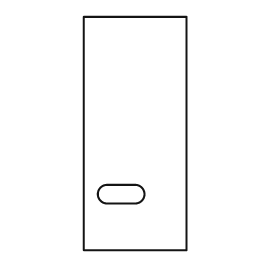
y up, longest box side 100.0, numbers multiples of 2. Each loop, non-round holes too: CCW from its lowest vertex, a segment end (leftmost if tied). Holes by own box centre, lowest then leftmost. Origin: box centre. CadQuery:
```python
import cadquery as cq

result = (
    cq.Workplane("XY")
    .moveTo(-22.0, -50.0)
    .lineTo(22.0, -50.0)
    .lineTo(22.0, 50.0)
    .lineTo(-22.0, 50.0)
    .close()
    .moveTo(-12.0, -30.0)
    .lineTo(0.0, -30.0)
    .threePointArc((4.0, -26.0), (0.0, -22.0))
    .lineTo(-12.0, -22.0)
    .threePointArc((-16.0, -26.0), (-12.0, -30.0))
    .close()
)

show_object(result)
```